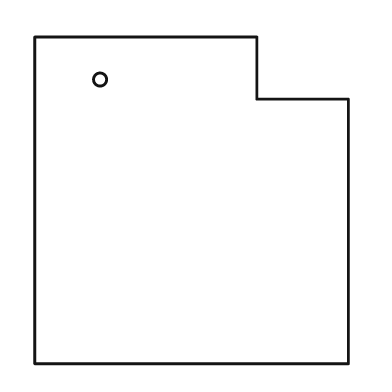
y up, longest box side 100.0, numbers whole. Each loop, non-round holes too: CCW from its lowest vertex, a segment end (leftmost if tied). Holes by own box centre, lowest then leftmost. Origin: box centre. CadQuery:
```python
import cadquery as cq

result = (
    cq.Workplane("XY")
    .moveTo(-48.0, -50.0)
    .lineTo(48.0, -50.0)
    .lineTo(48.0, 31.0)
    .lineTo(20.0, 31.0)
    .lineTo(20.0, 50.0)
    .lineTo(-48.0, 50.0)
    .close()
    .moveTo(-28.0, 37.0)
    .circle(2.0)
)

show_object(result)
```